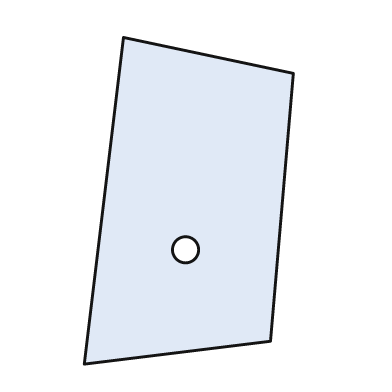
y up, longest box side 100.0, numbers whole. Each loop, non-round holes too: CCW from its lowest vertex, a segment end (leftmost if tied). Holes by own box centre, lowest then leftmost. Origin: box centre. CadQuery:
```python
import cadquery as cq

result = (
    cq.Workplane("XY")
    .moveTo(-32.0, -50.0)
    .lineTo(25.0, -43.0)
    .lineTo(32.0, 39.0)
    .lineTo(-20.0, 50.0)
    .close()
    .moveTo(-1.0, -15.0)
    .circle(4.0)
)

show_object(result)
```